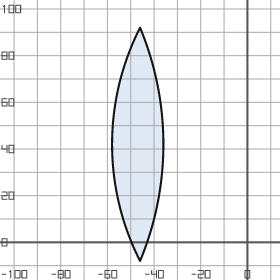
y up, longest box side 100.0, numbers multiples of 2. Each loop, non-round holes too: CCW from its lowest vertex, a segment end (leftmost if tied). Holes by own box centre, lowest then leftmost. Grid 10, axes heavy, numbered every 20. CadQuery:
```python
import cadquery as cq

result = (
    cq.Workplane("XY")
    .moveTo(-46.0, -8.0)
    .threePointArc((-36.0, 42.0), (-46.0, 92.0))
    .threePointArc((-58.0, 42.0), (-46.0, -8.0))
    .close()
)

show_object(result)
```